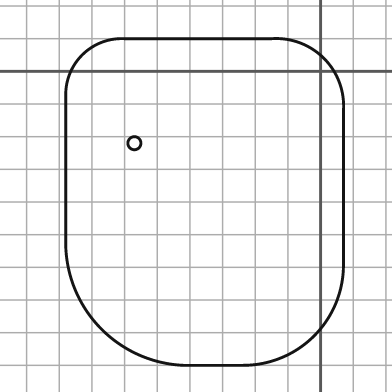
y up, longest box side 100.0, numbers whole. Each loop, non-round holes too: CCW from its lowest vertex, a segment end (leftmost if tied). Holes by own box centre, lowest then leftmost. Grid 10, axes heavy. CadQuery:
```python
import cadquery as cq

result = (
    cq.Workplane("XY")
    .moveTo(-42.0, -90.0)
    .lineTo(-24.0, -90.0)
    .threePointArc((-2.0, -81.0), (7.0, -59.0))
    .lineTo(7.0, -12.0)
    .threePointArc((1.0, 4.0), (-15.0, 10.0))
    .lineTo(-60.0, 10.0)
    .threePointArc((-73.0, 5.0), (-78.0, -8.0))
    .lineTo(-78.0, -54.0)
    .threePointArc((-67.0, -79.0), (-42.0, -90.0))
    .close()
    .moveTo(-57.0, -22.0)
    .circle(2.0)
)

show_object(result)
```